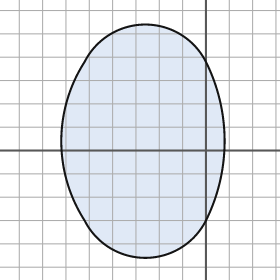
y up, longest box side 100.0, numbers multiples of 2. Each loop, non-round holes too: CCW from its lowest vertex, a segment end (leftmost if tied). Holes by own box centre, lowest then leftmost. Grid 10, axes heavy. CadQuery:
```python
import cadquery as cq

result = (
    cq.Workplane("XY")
    .moveTo(-52.0, -30.0)
    .threePointArc((-26.0, -46.0), (0.0, -30.0))
    .threePointArc((8.0, 4.0), (0.0, 38.0))
    .threePointArc((-26.0, 54.0), (-52.0, 38.0))
    .threePointArc((-62.0, 4.0), (-52.0, -30.0))
    .close()
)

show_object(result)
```